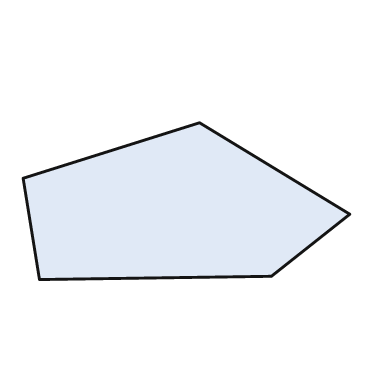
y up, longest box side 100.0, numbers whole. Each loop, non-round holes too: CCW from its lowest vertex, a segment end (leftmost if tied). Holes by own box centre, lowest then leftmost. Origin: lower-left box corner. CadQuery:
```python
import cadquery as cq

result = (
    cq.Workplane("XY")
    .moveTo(5.0, 0.0)
    .lineTo(76.0, 1.0)
    .lineTo(100.0, 20.0)
    .lineTo(54.0, 48.0)
    .lineTo(0.0, 31.0)
    .close()
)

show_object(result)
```